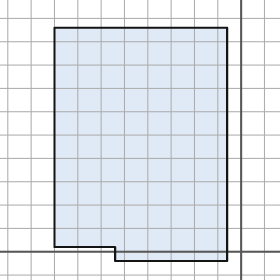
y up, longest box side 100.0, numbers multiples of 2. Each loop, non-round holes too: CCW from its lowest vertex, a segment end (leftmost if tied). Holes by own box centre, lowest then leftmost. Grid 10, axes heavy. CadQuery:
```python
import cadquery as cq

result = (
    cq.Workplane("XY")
    .moveTo(-54.0, -4.0)
    .lineTo(-6.0, -4.0)
    .lineTo(-6.0, 96.0)
    .lineTo(-80.0, 96.0)
    .lineTo(-80.0, 2.0)
    .lineTo(-54.0, 2.0)
    .close()
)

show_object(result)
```